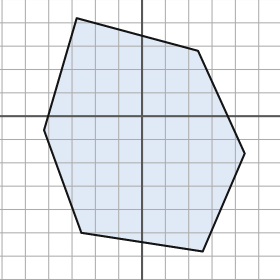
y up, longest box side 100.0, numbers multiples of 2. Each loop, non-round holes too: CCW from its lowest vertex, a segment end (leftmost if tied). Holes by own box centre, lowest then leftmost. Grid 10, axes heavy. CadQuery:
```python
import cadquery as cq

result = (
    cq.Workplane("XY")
    .moveTo(26.0, -58.0)
    .lineTo(44.0, -16.0)
    .lineTo(24.0, 28.0)
    .lineTo(-28.0, 42.0)
    .lineTo(-42.0, -6.0)
    .lineTo(-26.0, -50.0)
    .close()
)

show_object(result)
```